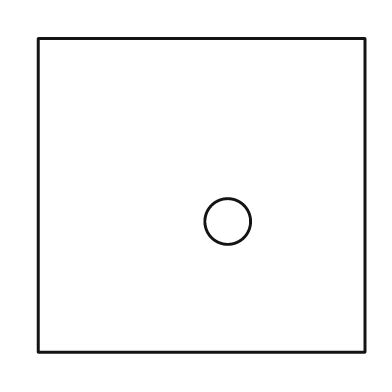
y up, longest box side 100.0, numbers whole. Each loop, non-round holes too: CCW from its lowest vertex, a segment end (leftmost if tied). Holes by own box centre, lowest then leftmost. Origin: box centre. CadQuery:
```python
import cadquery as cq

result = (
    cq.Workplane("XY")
    .moveTo(-50.0, -48.0)
    .lineTo(50.0, -48.0)
    .lineTo(50.0, 48.0)
    .lineTo(-50.0, 48.0)
    .close()
    .moveTo(8.0, -8.0)
    .circle(7.0)
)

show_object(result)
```